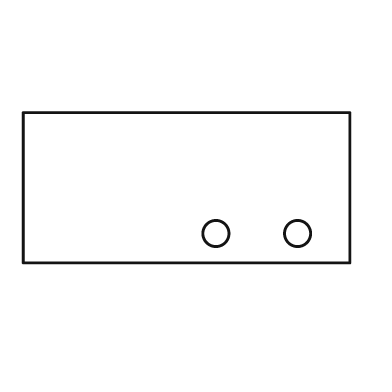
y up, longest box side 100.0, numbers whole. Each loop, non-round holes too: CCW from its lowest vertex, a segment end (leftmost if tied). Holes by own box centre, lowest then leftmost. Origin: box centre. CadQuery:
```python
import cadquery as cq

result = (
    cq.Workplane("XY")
    .moveTo(-50.0, -23.0)
    .lineTo(50.0, -23.0)
    .lineTo(50.0, 23.0)
    .lineTo(-50.0, 23.0)
    .close()
    .moveTo(9.0, -14.0)
    .circle(4.0)
    .moveTo(34.0, -14.0)
    .circle(4.0)
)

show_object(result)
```